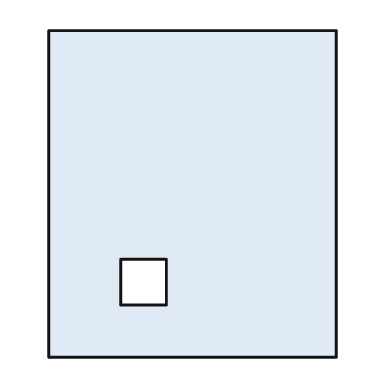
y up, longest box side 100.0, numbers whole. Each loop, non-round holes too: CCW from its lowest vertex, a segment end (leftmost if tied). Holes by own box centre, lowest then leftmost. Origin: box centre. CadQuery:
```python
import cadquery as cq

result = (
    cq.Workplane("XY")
    .moveTo(-44.0, -50.0)
    .lineTo(44.0, -50.0)
    .lineTo(44.0, 50.0)
    .lineTo(-44.0, 50.0)
    .close()
    .moveTo(-22.0, -34.0)
    .lineTo(-8.0, -34.0)
    .lineTo(-8.0, -20.0)
    .lineTo(-22.0, -20.0)
    .close()
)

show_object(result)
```